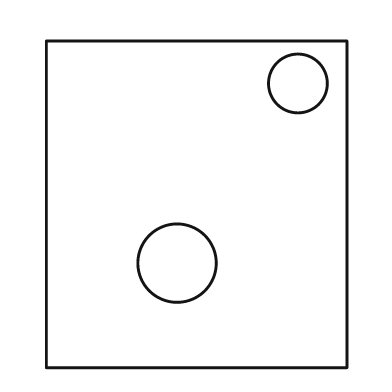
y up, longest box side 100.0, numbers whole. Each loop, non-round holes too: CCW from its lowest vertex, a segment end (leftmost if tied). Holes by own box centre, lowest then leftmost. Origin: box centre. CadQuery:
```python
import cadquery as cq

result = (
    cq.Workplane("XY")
    .moveTo(-46.0, -50.0)
    .lineTo(46.0, -50.0)
    .lineTo(46.0, 50.0)
    .lineTo(-46.0, 50.0)
    .close()
    .moveTo(-6.0, -18.0)
    .circle(12.0)
    .moveTo(31.0, 37.0)
    .circle(9.0)
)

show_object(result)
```